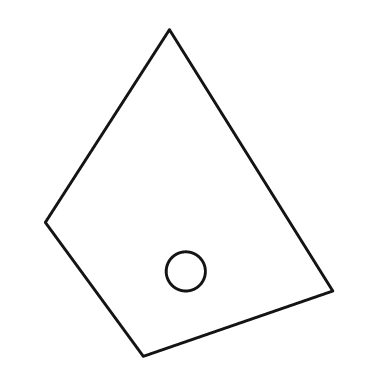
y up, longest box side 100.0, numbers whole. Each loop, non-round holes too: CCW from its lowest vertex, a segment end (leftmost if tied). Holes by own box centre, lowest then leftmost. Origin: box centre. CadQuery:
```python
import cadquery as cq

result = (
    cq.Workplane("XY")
    .moveTo(-14.0, -50.0)
    .lineTo(44.0, -30.0)
    .lineTo(-6.0, 50.0)
    .lineTo(-44.0, -9.0)
    .close()
    .moveTo(-1.0, -24.0)
    .circle(6.0)
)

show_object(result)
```